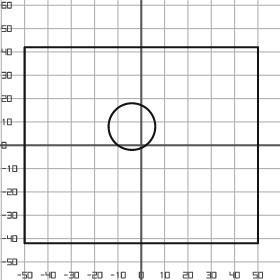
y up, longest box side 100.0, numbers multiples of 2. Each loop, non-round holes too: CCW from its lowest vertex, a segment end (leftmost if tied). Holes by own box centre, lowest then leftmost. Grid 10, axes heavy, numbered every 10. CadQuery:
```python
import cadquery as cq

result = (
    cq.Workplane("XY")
    .moveTo(-50.0, -42.0)
    .lineTo(50.0, -42.0)
    .lineTo(50.0, 42.0)
    .lineTo(-50.0, 42.0)
    .close()
    .moveTo(-4.0, 8.0)
    .circle(10.0)
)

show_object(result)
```